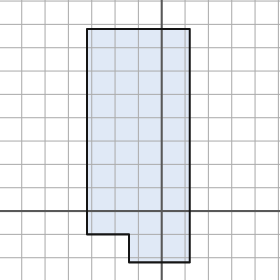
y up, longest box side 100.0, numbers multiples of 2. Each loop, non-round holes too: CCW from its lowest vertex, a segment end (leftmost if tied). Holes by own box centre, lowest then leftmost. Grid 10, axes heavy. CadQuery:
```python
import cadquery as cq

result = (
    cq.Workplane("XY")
    .moveTo(-14.0, -22.0)
    .lineTo(12.0, -22.0)
    .lineTo(12.0, 78.0)
    .lineTo(-32.0, 78.0)
    .lineTo(-32.0, -10.0)
    .lineTo(-14.0, -10.0)
    .close()
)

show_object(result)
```